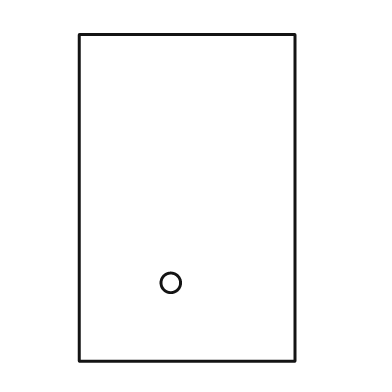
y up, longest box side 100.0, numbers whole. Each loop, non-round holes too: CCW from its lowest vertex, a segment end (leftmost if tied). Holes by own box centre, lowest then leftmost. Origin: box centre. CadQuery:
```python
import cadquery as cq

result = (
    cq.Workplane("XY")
    .moveTo(-33.0, -50.0)
    .lineTo(33.0, -50.0)
    .lineTo(33.0, 50.0)
    .lineTo(-33.0, 50.0)
    .close()
    .moveTo(-5.0, -26.0)
    .circle(3.0)
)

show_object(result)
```